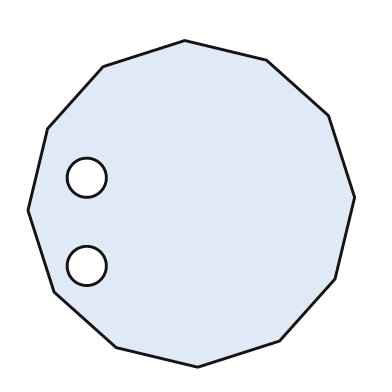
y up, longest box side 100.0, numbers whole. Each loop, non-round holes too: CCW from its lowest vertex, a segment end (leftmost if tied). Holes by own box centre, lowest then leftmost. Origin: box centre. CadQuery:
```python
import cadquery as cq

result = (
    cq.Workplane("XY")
    .moveTo(2.0, -50.0)
    .lineTo(27.0, -42.0)
    .lineTo(44.0, -23.0)
    .lineTo(50.0, 2.0)
    .lineTo(42.0, 27.0)
    .lineTo(23.0, 44.0)
    .lineTo(-2.0, 50.0)
    .lineTo(-27.0, 42.0)
    .lineTo(-44.0, 23.0)
    .lineTo(-50.0, -2.0)
    .lineTo(-42.0, -27.0)
    .lineTo(-23.0, -44.0)
    .close()
    .moveTo(-32.0, -19.0)
    .circle(6.0)
    .moveTo(-32.0, 8.0)
    .circle(6.0)
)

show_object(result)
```